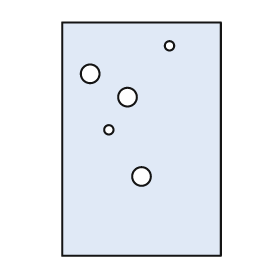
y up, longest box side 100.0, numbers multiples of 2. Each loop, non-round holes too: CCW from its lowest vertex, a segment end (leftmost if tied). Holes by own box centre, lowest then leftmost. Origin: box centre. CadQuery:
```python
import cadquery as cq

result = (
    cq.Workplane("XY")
    .moveTo(-34.0, -50.0)
    .lineTo(34.0, -50.0)
    .lineTo(34.0, 50.0)
    .lineTo(-34.0, 50.0)
    .close()
    .moveTo(0.0, -16.0)
    .circle(4.0)
    .moveTo(-14.0, 4.0)
    .circle(2.0)
    .moveTo(-6.0, 18.0)
    .circle(4.0)
    .moveTo(-22.0, 28.0)
    .circle(4.0)
    .moveTo(12.0, 40.0)
    .circle(2.0)
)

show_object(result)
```